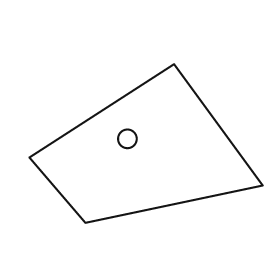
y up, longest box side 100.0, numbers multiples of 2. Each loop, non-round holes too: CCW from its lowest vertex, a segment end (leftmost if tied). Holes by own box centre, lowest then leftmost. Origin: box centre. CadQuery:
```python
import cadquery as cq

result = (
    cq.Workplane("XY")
    .moveTo(-26.0, -34.0)
    .lineTo(50.0, -18.0)
    .lineTo(12.0, 34.0)
    .lineTo(-50.0, -6.0)
    .close()
    .moveTo(-8.0, 2.0)
    .circle(4.0)
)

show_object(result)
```